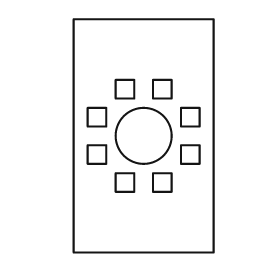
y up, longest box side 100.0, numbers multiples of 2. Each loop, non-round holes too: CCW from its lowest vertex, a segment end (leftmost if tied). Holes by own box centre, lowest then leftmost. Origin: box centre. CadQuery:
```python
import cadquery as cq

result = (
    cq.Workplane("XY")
    .moveTo(-30.0, -50.0)
    .lineTo(30.0, -50.0)
    .lineTo(30.0, 50.0)
    .lineTo(-30.0, 50.0)
    .close()
    .moveTo(-12.0, -24.0)
    .lineTo(-4.0, -24.0)
    .lineTo(-4.0, -16.0)
    .lineTo(-12.0, -16.0)
    .close()
    .moveTo(4.0, -24.0)
    .lineTo(12.0, -24.0)
    .lineTo(12.0, -16.0)
    .lineTo(4.0, -16.0)
    .close()
    .moveTo(-24.0, -12.0)
    .lineTo(-16.0, -12.0)
    .lineTo(-16.0, -4.0)
    .lineTo(-24.0, -4.0)
    .close()
    .moveTo(16.0, -12.0)
    .lineTo(24.0, -12.0)
    .lineTo(24.0, -4.0)
    .lineTo(16.0, -4.0)
    .close()
    .moveTo(0.0, 0.0)
    .circle(12.0)
    .moveTo(-24.0, 4.0)
    .lineTo(-16.0, 4.0)
    .lineTo(-16.0, 12.0)
    .lineTo(-24.0, 12.0)
    .close()
    .moveTo(16.0, 4.0)
    .lineTo(24.0, 4.0)
    .lineTo(24.0, 12.0)
    .lineTo(16.0, 12.0)
    .close()
    .moveTo(-12.0, 16.0)
    .lineTo(-4.0, 16.0)
    .lineTo(-4.0, 24.0)
    .lineTo(-12.0, 24.0)
    .close()
    .moveTo(4.0, 16.0)
    .lineTo(12.0, 16.0)
    .lineTo(12.0, 24.0)
    .lineTo(4.0, 24.0)
    .close()
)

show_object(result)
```